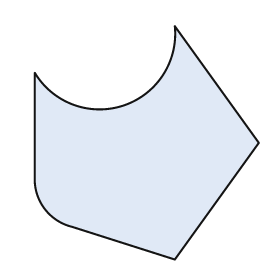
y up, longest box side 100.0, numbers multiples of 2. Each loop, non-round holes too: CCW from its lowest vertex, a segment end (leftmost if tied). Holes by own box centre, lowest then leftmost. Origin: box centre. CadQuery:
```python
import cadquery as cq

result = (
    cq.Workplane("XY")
    .moveTo(12.0, -50.0)
    .lineTo(48.0, 0.0)
    .lineTo(12.0, 50.0)
    .threePointArc((-10.0, 16.0), (-48.0, 30.0))
    .lineTo(-48.0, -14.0)
    .threePointArc((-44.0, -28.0), (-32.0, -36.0))
    .close()
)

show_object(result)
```